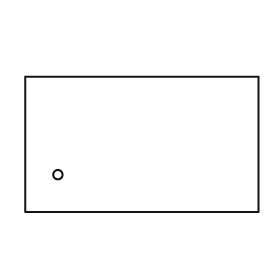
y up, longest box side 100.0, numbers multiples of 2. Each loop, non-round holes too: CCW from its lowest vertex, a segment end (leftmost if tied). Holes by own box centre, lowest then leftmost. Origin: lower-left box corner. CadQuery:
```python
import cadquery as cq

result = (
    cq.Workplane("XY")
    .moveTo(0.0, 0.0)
    .lineTo(100.0, 0.0)
    .lineTo(100.0, 58.0)
    .lineTo(0.0, 58.0)
    .close()
    .moveTo(14.0, 16.0)
    .circle(2.0)
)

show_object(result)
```